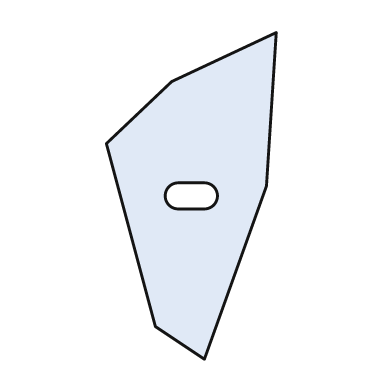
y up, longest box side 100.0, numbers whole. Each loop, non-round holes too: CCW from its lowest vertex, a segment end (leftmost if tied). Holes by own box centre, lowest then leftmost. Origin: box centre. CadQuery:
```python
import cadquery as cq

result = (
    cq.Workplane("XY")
    .moveTo(4.0, -50.0)
    .lineTo(23.0, 3.0)
    .lineTo(26.0, 50.0)
    .lineTo(-6.0, 35.0)
    .lineTo(-26.0, 16.0)
    .lineTo(-11.0, -40.0)
    .close()
    .moveTo(-4.0, -4.0)
    .lineTo(4.0, -4.0)
    .threePointArc((8.0, 0.0), (4.0, 4.0))
    .lineTo(-4.0, 4.0)
    .threePointArc((-8.0, 0.0), (-4.0, -4.0))
    .close()
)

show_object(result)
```